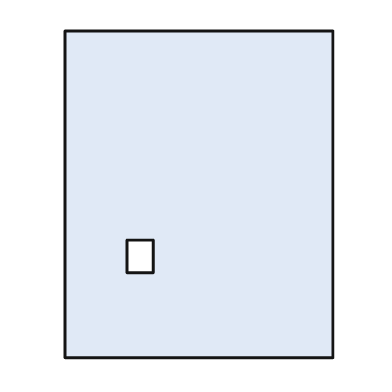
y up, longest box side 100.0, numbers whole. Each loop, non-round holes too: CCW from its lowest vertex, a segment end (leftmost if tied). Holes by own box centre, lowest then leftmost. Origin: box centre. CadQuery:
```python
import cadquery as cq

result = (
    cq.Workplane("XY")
    .moveTo(-41.0, -50.0)
    .lineTo(41.0, -50.0)
    .lineTo(41.0, 50.0)
    .lineTo(-41.0, 50.0)
    .close()
    .moveTo(-22.0, -24.0)
    .lineTo(-14.0, -24.0)
    .lineTo(-14.0, -14.0)
    .lineTo(-22.0, -14.0)
    .close()
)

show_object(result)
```